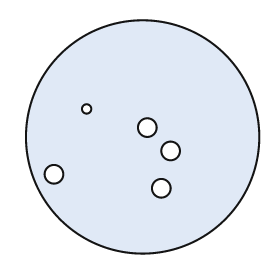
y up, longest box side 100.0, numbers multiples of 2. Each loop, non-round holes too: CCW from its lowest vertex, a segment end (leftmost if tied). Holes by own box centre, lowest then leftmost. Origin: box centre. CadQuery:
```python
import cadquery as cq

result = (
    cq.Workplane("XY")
    .moveTo(0.0, 0.0)
    .circle(50.0)
    .moveTo(8.0, -22.0)
    .circle(4.0)
    .moveTo(-38.0, -16.0)
    .circle(4.0)
    .moveTo(12.0, -6.0)
    .circle(4.0)
    .moveTo(2.0, 4.0)
    .circle(4.0)
    .moveTo(-24.0, 12.0)
    .circle(2.0)
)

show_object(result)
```